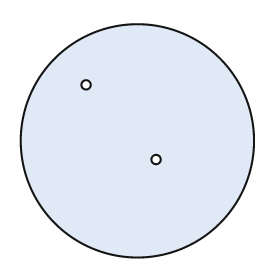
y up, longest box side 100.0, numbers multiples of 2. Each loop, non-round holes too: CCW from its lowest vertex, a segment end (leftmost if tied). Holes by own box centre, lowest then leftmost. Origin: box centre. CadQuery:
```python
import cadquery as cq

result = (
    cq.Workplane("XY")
    .moveTo(0.0, 0.0)
    .circle(50.0)
    .moveTo(8.0, -8.0)
    .circle(2.0)
    .moveTo(-22.0, 24.0)
    .circle(2.0)
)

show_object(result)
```